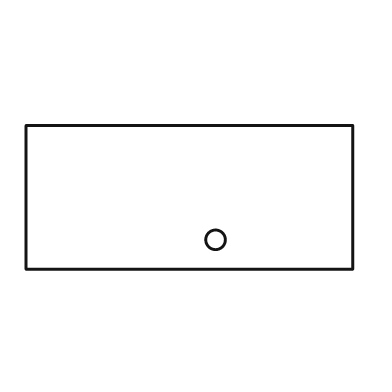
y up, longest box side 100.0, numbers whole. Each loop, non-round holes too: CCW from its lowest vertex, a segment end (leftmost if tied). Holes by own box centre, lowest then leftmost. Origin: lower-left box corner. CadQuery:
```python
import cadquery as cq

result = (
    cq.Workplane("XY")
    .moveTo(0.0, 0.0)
    .lineTo(100.0, 0.0)
    .lineTo(100.0, 44.0)
    .lineTo(0.0, 44.0)
    .close()
    .moveTo(58.0, 9.0)
    .circle(3.0)
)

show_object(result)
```